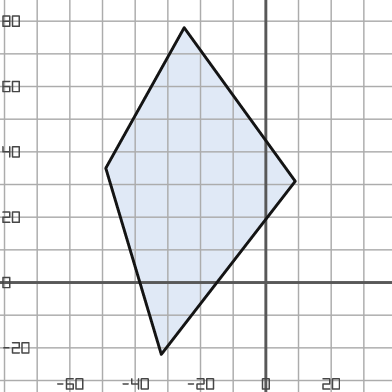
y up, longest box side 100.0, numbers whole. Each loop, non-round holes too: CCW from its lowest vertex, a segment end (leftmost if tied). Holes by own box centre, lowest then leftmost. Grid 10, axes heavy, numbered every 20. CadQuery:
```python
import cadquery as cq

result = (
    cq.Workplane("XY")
    .moveTo(-32.0, -22.0)
    .lineTo(9.0, 31.0)
    .lineTo(-25.0, 78.0)
    .lineTo(-49.0, 35.0)
    .close()
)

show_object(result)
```